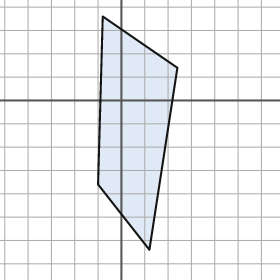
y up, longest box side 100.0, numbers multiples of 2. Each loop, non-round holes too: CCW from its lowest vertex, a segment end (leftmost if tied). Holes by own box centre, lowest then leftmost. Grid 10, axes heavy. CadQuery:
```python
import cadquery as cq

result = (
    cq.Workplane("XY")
    .moveTo(12.0, -64.0)
    .lineTo(24.0, 14.0)
    .lineTo(-8.0, 36.0)
    .lineTo(-10.0, -36.0)
    .close()
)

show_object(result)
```